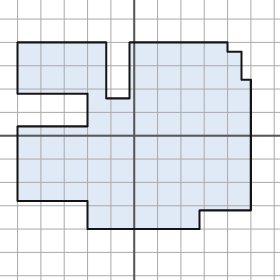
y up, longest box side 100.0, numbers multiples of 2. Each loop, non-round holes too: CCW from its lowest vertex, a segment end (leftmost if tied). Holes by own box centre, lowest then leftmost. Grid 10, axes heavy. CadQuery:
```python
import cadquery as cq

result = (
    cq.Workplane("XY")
    .moveTo(-20.0, -40.0)
    .lineTo(28.0, -40.0)
    .lineTo(28.0, -32.0)
    .lineTo(50.0, -32.0)
    .lineTo(50.0, 24.0)
    .lineTo(46.0, 24.0)
    .lineTo(46.0, 36.0)
    .lineTo(40.0, 36.0)
    .lineTo(40.0, 40.0)
    .lineTo(-2.0, 40.0)
    .lineTo(-2.0, 16.0)
    .lineTo(-12.0, 16.0)
    .lineTo(-12.0, 40.0)
    .lineTo(-50.0, 40.0)
    .lineTo(-50.0, 18.0)
    .lineTo(-20.0, 18.0)
    .lineTo(-20.0, 4.0)
    .lineTo(-50.0, 4.0)
    .lineTo(-50.0, -28.0)
    .lineTo(-20.0, -28.0)
    .close()
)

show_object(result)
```